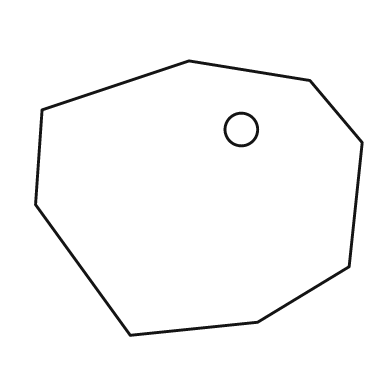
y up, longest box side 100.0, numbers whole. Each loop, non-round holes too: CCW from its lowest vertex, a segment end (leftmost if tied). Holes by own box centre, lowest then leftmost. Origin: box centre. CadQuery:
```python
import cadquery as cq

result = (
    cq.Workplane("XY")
    .moveTo(-21.0, -42.0)
    .lineTo(18.0, -38.0)
    .lineTo(46.0, -21.0)
    .lineTo(50.0, 17.0)
    .lineTo(34.0, 36.0)
    .lineTo(-3.0, 42.0)
    .lineTo(-48.0, 27.0)
    .lineTo(-50.0, -2.0)
    .close()
    .moveTo(13.0, 21.0)
    .circle(5.0)
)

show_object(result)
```